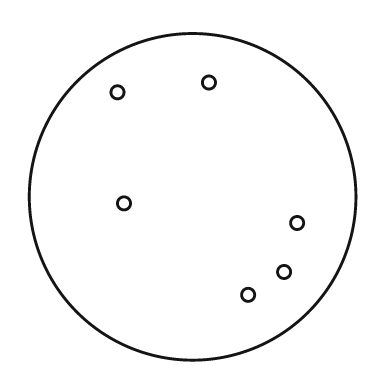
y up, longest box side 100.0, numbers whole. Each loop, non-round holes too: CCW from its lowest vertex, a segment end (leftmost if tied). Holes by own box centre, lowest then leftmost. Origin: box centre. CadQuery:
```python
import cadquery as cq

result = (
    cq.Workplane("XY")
    .moveTo(0.0, 0.0)
    .circle(50.0)
    .moveTo(17.0, -30.0)
    .circle(2.0)
    .moveTo(28.0, -23.0)
    .circle(2.0)
    .moveTo(32.0, -8.0)
    .circle(2.0)
    .moveTo(-21.0, -2.0)
    .circle(2.0)
    .moveTo(-23.0, 32.0)
    .circle(2.0)
    .moveTo(5.0, 35.0)
    .circle(2.0)
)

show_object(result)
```